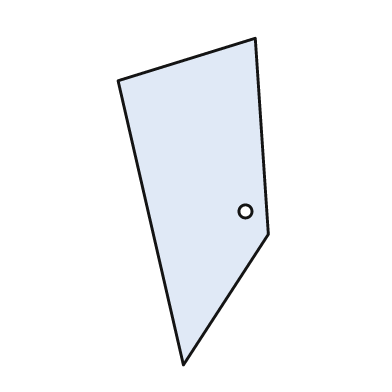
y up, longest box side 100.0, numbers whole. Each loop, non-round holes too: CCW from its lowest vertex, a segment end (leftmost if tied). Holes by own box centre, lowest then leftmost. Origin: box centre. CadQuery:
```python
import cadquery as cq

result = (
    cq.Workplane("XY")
    .moveTo(-3.0, -50.0)
    .lineTo(23.0, -10.0)
    .lineTo(19.0, 50.0)
    .lineTo(-23.0, 37.0)
    .close()
    .moveTo(16.0, -3.0)
    .circle(2.0)
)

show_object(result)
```